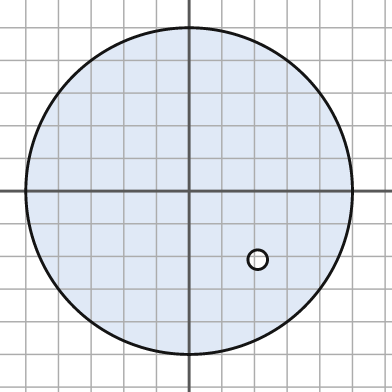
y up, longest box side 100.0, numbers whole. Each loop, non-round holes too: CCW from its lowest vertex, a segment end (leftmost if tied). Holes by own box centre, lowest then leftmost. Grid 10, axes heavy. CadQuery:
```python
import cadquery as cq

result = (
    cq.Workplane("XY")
    .moveTo(0.0, 0.0)
    .circle(50.0)
    .moveTo(21.0, -21.0)
    .circle(3.0)
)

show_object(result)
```